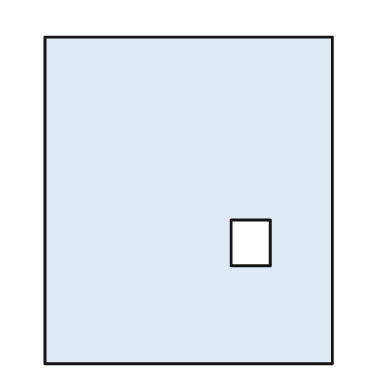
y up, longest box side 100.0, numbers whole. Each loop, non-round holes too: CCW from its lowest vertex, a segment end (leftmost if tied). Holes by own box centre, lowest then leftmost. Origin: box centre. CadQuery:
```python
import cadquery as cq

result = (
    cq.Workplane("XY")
    .moveTo(-44.0, -50.0)
    .lineTo(44.0, -50.0)
    .lineTo(44.0, 50.0)
    .lineTo(-44.0, 50.0)
    .close()
    .moveTo(13.0, -20.0)
    .lineTo(25.0, -20.0)
    .lineTo(25.0, -6.0)
    .lineTo(13.0, -6.0)
    .close()
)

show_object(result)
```